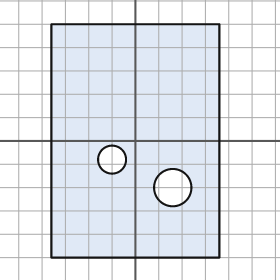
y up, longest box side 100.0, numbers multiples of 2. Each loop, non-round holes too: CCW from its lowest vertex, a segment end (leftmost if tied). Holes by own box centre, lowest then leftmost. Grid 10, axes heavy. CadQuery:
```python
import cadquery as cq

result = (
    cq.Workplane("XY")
    .moveTo(-36.0, -50.0)
    .lineTo(36.0, -50.0)
    .lineTo(36.0, 50.0)
    .lineTo(-36.0, 50.0)
    .close()
    .moveTo(16.0, -20.0)
    .circle(8.0)
    .moveTo(-10.0, -8.0)
    .circle(6.0)
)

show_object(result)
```